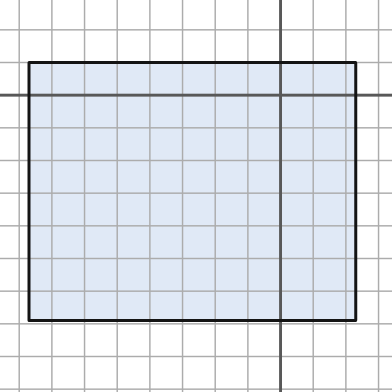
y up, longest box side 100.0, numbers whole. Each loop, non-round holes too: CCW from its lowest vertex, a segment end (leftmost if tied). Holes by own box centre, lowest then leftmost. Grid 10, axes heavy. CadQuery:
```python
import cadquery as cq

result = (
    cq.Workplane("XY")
    .moveTo(-77.0, -69.0)
    .lineTo(23.0, -69.0)
    .lineTo(23.0, 10.0)
    .lineTo(-77.0, 10.0)
    .close()
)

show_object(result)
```